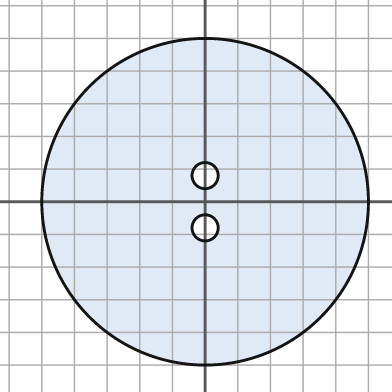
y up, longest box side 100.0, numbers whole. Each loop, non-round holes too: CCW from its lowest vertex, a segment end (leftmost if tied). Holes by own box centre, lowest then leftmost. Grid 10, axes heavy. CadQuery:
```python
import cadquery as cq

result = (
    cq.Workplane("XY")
    .moveTo(0.0, 0.0)
    .circle(50.0)
    .moveTo(0.0, -8.0)
    .circle(4.0)
    .moveTo(0.0, 8.0)
    .circle(4.0)
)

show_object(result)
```